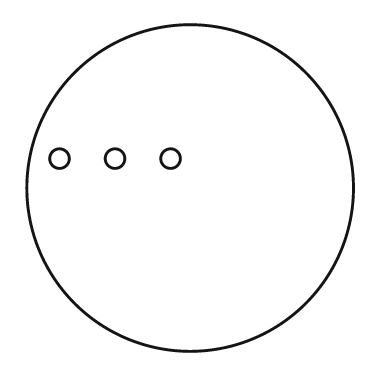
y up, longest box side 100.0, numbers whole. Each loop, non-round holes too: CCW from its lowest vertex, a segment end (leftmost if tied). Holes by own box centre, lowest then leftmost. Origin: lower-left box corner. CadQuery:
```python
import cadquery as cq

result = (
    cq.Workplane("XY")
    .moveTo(50.0, 50.0)
    .circle(50.0)
    .moveTo(10.0, 59.0)
    .circle(3.0)
    .moveTo(27.0, 59.0)
    .circle(3.0)
    .moveTo(44.0, 59.0)
    .circle(3.0)
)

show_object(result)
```